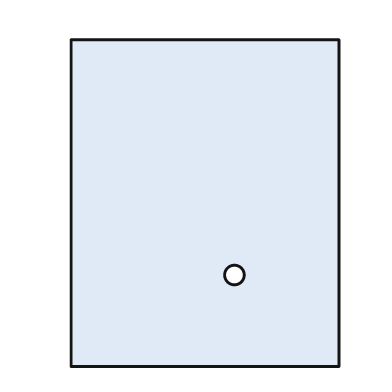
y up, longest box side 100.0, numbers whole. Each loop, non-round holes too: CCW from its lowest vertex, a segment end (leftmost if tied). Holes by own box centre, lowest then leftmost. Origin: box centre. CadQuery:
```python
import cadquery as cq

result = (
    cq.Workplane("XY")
    .moveTo(-41.0, -50.0)
    .lineTo(41.0, -50.0)
    .lineTo(41.0, 50.0)
    .lineTo(-41.0, 50.0)
    .close()
    .moveTo(9.0, -22.0)
    .circle(3.0)
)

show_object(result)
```